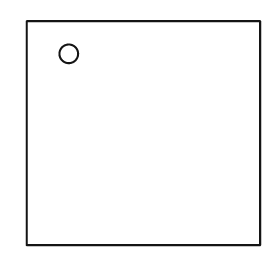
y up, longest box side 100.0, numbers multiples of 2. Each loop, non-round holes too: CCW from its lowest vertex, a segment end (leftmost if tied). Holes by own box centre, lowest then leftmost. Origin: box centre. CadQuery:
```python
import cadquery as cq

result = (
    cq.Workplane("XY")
    .moveTo(-50.0, -48.0)
    .lineTo(50.0, -48.0)
    .lineTo(50.0, 48.0)
    .lineTo(-50.0, 48.0)
    .close()
    .moveTo(-32.0, 34.0)
    .circle(4.0)
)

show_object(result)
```